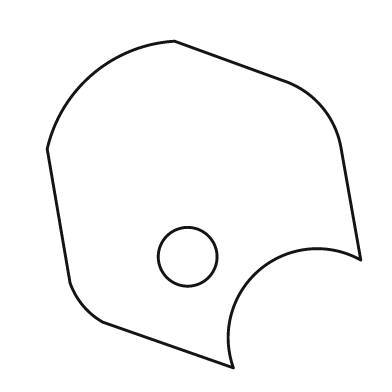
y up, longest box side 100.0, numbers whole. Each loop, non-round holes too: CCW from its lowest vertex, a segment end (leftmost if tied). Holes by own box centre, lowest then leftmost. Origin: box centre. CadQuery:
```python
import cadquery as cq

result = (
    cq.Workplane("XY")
    .moveTo(9.0, -50.0)
    .threePointArc((17.0, -20.0), (48.0, -17.0))
    .lineTo(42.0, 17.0)
    .threePointArc((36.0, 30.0), (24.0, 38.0))
    .lineTo(-9.0, 50.0)
    .threePointArc((-34.0, 40.0), (-48.0, 17.0))
    .lineTo(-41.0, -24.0)
    .threePointArc((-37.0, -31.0), (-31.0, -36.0))
    .close()
    .moveTo(-5.0, -16.0)
    .circle(9.0)
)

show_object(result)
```